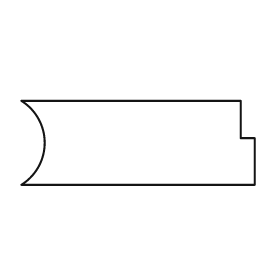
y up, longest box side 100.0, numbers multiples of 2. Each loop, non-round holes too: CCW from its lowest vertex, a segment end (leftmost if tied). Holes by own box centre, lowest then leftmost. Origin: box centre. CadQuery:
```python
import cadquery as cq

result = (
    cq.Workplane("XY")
    .moveTo(-50.0, -18.0)
    .lineTo(50.0, -18.0)
    .lineTo(50.0, 2.0)
    .lineTo(44.0, 2.0)
    .lineTo(44.0, 18.0)
    .lineTo(-50.0, 18.0)
    .threePointArc((-40.0, 0.0), (-50.0, -18.0))
    .close()
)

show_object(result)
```